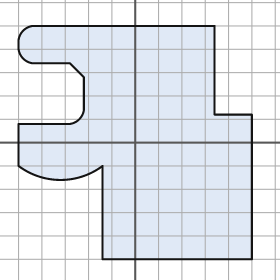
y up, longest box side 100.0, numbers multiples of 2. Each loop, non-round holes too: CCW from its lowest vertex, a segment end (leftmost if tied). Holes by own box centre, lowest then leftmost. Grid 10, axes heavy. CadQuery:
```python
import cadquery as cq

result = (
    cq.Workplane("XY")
    .moveTo(-14.0, -50.0)
    .lineTo(50.0, -50.0)
    .lineTo(50.0, 12.0)
    .lineTo(34.0, 12.0)
    .lineTo(34.0, 50.0)
    .lineTo(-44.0, 50.0)
    .threePointArc((-48.0, 48.0), (-50.0, 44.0))
    .lineTo(-50.0, 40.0)
    .threePointArc((-48.0, 36.0), (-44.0, 34.0))
    .lineTo(-28.0, 34.0)
    .lineTo(-22.0, 28.0)
    .lineTo(-22.0, 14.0)
    .threePointArc((-24.0, 10.0), (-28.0, 8.0))
    .lineTo(-50.0, 8.0)
    .lineTo(-50.0, -10.0)
    .threePointArc((-32.0, -16.0), (-14.0, -10.0))
    .close()
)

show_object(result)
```